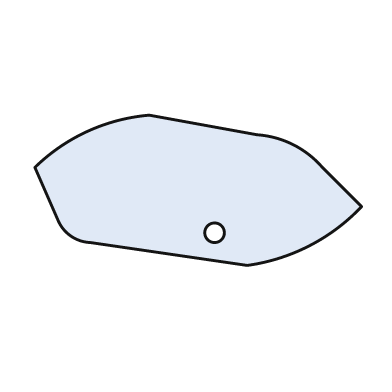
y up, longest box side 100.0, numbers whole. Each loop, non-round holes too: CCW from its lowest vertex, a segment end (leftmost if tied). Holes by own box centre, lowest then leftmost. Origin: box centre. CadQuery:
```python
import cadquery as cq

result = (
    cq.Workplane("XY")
    .moveTo(15.0, -23.0)
    .threePointArc((34.0, -17.0), (50.0, -5.0))
    .lineTo(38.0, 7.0)
    .threePointArc((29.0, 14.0), (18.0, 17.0))
    .lineTo(-15.0, 23.0)
    .threePointArc((-34.0, 18.0), (-50.0, 7.0))
    .lineTo(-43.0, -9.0)
    .threePointArc((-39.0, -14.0), (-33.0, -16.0))
    .close()
    .moveTo(5.0, -13.0)
    .circle(3.0)
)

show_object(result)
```